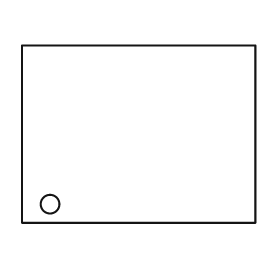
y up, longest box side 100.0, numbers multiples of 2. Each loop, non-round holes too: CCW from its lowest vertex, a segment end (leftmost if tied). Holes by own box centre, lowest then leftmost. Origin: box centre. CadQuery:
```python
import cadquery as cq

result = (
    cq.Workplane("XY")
    .moveTo(-50.0, -38.0)
    .lineTo(50.0, -38.0)
    .lineTo(50.0, 38.0)
    .lineTo(-50.0, 38.0)
    .close()
    .moveTo(-38.0, -30.0)
    .circle(4.0)
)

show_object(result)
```